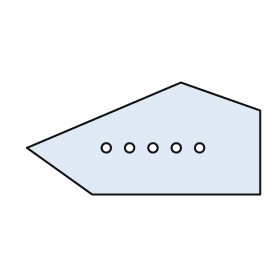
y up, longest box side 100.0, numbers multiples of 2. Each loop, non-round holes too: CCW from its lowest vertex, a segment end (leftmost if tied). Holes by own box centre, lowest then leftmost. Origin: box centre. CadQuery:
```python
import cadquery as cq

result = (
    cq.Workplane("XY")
    .moveTo(-22.0, -24.0)
    .lineTo(50.0, -24.0)
    .lineTo(50.0, 12.0)
    .lineTo(16.0, 24.0)
    .lineTo(-50.0, -4.0)
    .close()
    .moveTo(-16.0, -4.0)
    .circle(2.0)
    .moveTo(-6.0, -4.0)
    .circle(2.0)
    .moveTo(4.0, -4.0)
    .circle(2.0)
    .moveTo(14.0, -4.0)
    .circle(2.0)
    .moveTo(24.0, -4.0)
    .circle(2.0)
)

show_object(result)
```